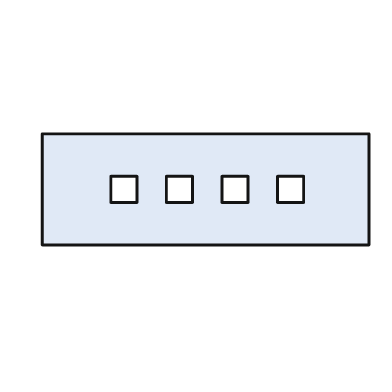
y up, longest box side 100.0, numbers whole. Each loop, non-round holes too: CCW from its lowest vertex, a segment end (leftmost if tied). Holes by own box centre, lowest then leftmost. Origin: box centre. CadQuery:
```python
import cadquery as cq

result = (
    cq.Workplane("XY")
    .moveTo(-50.0, -17.0)
    .lineTo(50.0, -17.0)
    .lineTo(50.0, 17.0)
    .lineTo(-50.0, 17.0)
    .close()
    .moveTo(-29.0, -4.0)
    .lineTo(-21.0, -4.0)
    .lineTo(-21.0, 4.0)
    .lineTo(-29.0, 4.0)
    .close()
    .moveTo(-12.0, -4.0)
    .lineTo(-4.0, -4.0)
    .lineTo(-4.0, 4.0)
    .lineTo(-12.0, 4.0)
    .close()
    .moveTo(5.0, -4.0)
    .lineTo(13.0, -4.0)
    .lineTo(13.0, 4.0)
    .lineTo(5.0, 4.0)
    .close()
    .moveTo(22.0, -4.0)
    .lineTo(30.0, -4.0)
    .lineTo(30.0, 4.0)
    .lineTo(22.0, 4.0)
    .close()
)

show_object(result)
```